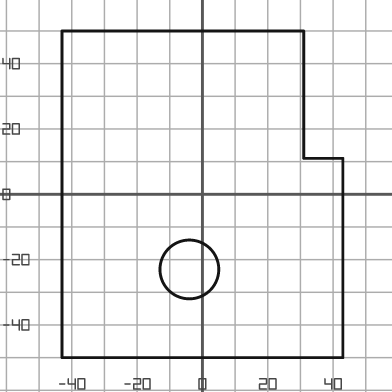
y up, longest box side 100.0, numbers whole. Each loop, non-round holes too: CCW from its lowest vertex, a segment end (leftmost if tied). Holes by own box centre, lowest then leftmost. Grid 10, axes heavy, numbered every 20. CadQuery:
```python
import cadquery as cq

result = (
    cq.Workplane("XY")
    .moveTo(-43.0, -50.0)
    .lineTo(43.0, -50.0)
    .lineTo(43.0, 11.0)
    .lineTo(31.0, 11.0)
    .lineTo(31.0, 50.0)
    .lineTo(-43.0, 50.0)
    .close()
    .moveTo(-4.0, -23.0)
    .circle(9.0)
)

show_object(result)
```